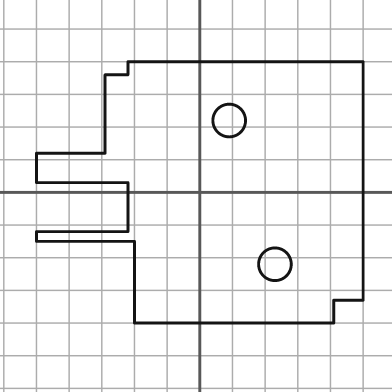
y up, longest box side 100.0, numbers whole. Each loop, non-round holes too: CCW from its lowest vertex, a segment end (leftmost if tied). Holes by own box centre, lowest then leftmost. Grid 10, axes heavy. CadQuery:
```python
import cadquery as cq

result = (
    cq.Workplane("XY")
    .moveTo(-20.0, -40.0)
    .lineTo(41.0, -40.0)
    .lineTo(41.0, -33.0)
    .lineTo(50.0, -33.0)
    .lineTo(50.0, 40.0)
    .lineTo(-22.0, 40.0)
    .lineTo(-22.0, 36.0)
    .lineTo(-29.0, 36.0)
    .lineTo(-29.0, 12.0)
    .lineTo(-50.0, 12.0)
    .lineTo(-50.0, 3.0)
    .lineTo(-22.0, 3.0)
    .lineTo(-22.0, -12.0)
    .lineTo(-50.0, -12.0)
    .lineTo(-50.0, -15.0)
    .lineTo(-20.0, -15.0)
    .close()
    .moveTo(23.0, -22.0)
    .circle(5.0)
    .moveTo(9.0, 22.0)
    .circle(5.0)
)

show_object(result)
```